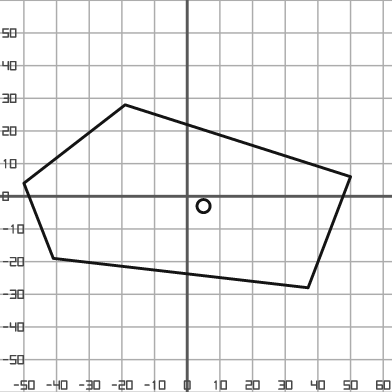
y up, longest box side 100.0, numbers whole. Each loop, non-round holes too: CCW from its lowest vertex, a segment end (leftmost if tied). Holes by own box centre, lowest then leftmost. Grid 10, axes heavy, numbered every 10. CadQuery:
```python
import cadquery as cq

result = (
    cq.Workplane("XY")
    .moveTo(37.0, -28.0)
    .lineTo(50.0, 6.0)
    .lineTo(-19.0, 28.0)
    .lineTo(-50.0, 4.0)
    .lineTo(-41.0, -19.0)
    .close()
    .moveTo(5.0, -3.0)
    .circle(2.0)
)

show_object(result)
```